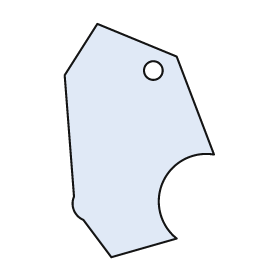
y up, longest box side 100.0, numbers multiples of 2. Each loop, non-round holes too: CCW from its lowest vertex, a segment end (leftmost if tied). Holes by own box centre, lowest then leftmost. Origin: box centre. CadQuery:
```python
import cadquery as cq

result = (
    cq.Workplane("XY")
    .moveTo(-12.0, -50.0)
    .lineTo(16.0, -42.0)
    .threePointArc((10.0, -18.0), (32.0, -6.0))
    .lineTo(16.0, 36.0)
    .lineTo(-18.0, 50.0)
    .lineTo(-32.0, 28.0)
    .lineTo(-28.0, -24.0)
    .threePointArc((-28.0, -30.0), (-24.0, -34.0))
    .close()
    .moveTo(6.0, 30.0)
    .circle(4.0)
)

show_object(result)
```